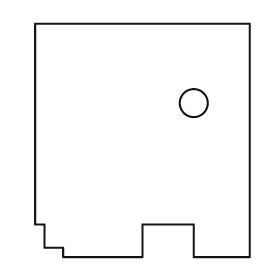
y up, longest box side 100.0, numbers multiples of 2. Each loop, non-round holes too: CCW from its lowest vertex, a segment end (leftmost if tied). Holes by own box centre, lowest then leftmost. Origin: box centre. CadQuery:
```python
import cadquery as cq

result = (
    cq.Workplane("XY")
    .moveTo(-34.0, -50.0)
    .lineTo(0.0, -50.0)
    .lineTo(0.0, -36.0)
    .lineTo(22.0, -36.0)
    .lineTo(22.0, -50.0)
    .lineTo(46.0, -50.0)
    .lineTo(46.0, 50.0)
    .lineTo(-46.0, 50.0)
    .lineTo(-46.0, -36.0)
    .lineTo(-42.0, -36.0)
    .lineTo(-42.0, -46.0)
    .lineTo(-34.0, -46.0)
    .close()
    .moveTo(22.0, 16.0)
    .circle(6.0)
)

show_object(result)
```